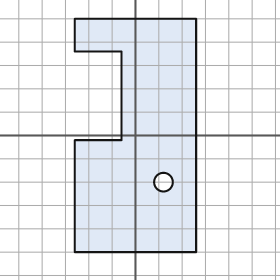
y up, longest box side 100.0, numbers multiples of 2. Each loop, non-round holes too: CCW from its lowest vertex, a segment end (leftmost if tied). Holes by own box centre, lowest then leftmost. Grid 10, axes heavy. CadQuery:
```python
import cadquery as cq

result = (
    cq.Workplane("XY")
    .moveTo(-26.0, -50.0)
    .lineTo(26.0, -50.0)
    .lineTo(26.0, 50.0)
    .lineTo(-26.0, 50.0)
    .lineTo(-26.0, 36.0)
    .lineTo(-6.0, 36.0)
    .lineTo(-6.0, -2.0)
    .lineTo(-26.0, -2.0)
    .close()
    .moveTo(12.0, -20.0)
    .circle(4.0)
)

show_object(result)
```